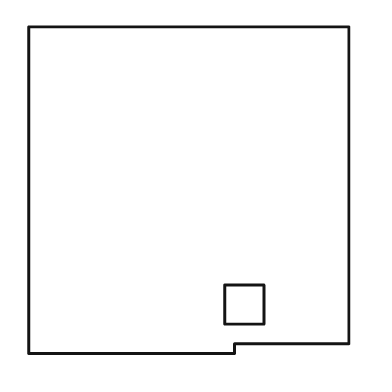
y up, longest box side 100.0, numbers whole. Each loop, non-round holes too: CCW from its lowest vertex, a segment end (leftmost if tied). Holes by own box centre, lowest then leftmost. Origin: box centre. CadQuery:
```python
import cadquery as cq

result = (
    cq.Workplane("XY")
    .moveTo(-49.0, -50.0)
    .lineTo(14.0, -50.0)
    .lineTo(14.0, -47.0)
    .lineTo(49.0, -47.0)
    .lineTo(49.0, 50.0)
    .lineTo(-49.0, 50.0)
    .close()
    .moveTo(11.0, -41.0)
    .lineTo(23.0, -41.0)
    .lineTo(23.0, -29.0)
    .lineTo(11.0, -29.0)
    .close()
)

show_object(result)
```